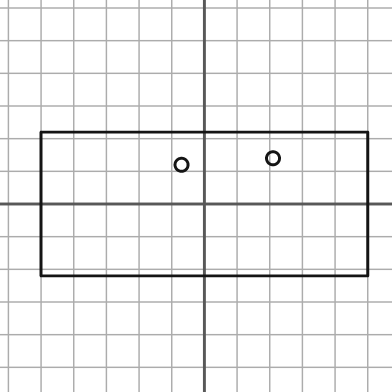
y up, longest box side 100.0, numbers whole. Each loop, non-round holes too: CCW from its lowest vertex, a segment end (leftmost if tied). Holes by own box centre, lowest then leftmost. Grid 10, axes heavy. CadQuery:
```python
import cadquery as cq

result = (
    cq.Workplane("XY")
    .moveTo(-50.0, -22.0)
    .lineTo(50.0, -22.0)
    .lineTo(50.0, 22.0)
    .lineTo(-50.0, 22.0)
    .close()
    .moveTo(-7.0, 12.0)
    .circle(2.0)
    .moveTo(21.0, 14.0)
    .circle(2.0)
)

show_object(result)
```